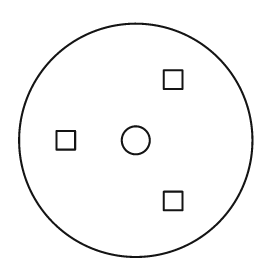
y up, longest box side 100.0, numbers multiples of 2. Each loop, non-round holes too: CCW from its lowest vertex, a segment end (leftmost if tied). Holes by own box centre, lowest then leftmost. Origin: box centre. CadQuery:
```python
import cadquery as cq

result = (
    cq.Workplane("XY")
    .moveTo(0.0, 0.0)
    .circle(50.0)
    .moveTo(12.0, -30.0)
    .lineTo(20.0, -30.0)
    .lineTo(20.0, -22.0)
    .lineTo(12.0, -22.0)
    .close()
    .moveTo(-34.0, -4.0)
    .lineTo(-26.0, -4.0)
    .lineTo(-26.0, 4.0)
    .lineTo(-34.0, 4.0)
    .close()
    .moveTo(0.0, 0.0)
    .circle(6.0)
    .moveTo(12.0, 22.0)
    .lineTo(20.0, 22.0)
    .lineTo(20.0, 30.0)
    .lineTo(12.0, 30.0)
    .close()
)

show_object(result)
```